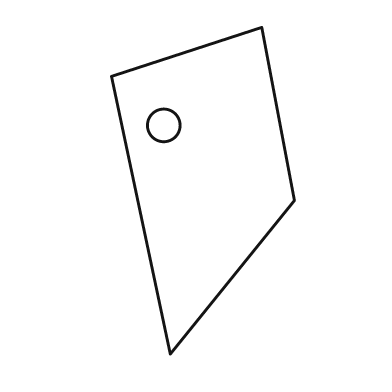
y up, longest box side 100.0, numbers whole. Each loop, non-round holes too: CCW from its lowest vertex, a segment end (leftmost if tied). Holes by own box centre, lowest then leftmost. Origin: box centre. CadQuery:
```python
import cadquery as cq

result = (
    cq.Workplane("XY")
    .moveTo(-10.0, -50.0)
    .lineTo(28.0, -3.0)
    .lineTo(18.0, 50.0)
    .lineTo(-28.0, 35.0)
    .close()
    .moveTo(-12.0, 20.0)
    .circle(5.0)
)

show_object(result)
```